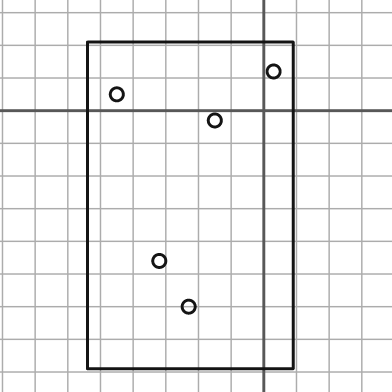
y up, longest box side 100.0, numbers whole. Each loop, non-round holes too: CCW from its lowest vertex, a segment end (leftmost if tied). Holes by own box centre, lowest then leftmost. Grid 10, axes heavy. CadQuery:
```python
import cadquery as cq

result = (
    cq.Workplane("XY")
    .moveTo(-54.0, -79.0)
    .lineTo(9.0, -79.0)
    .lineTo(9.0, 21.0)
    .lineTo(-54.0, 21.0)
    .close()
    .moveTo(-23.0, -60.0)
    .circle(2.0)
    .moveTo(-32.0, -46.0)
    .circle(2.0)
    .moveTo(-15.0, -3.0)
    .circle(2.0)
    .moveTo(-45.0, 5.0)
    .circle(2.0)
    .moveTo(3.0, 12.0)
    .circle(2.0)
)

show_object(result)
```